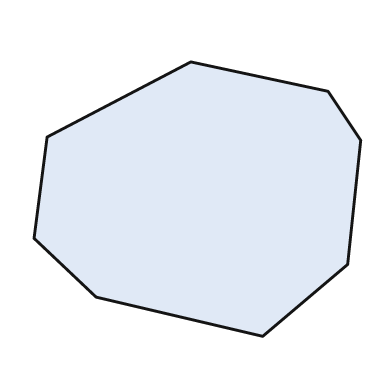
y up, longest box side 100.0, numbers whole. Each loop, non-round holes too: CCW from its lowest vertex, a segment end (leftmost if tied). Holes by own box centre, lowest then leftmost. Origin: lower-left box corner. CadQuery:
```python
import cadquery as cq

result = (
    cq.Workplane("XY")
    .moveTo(70.0, 0.0)
    .lineTo(96.0, 22.0)
    .lineTo(100.0, 60.0)
    .lineTo(90.0, 75.0)
    .lineTo(48.0, 84.0)
    .lineTo(4.0, 61.0)
    .lineTo(0.0, 30.0)
    .lineTo(19.0, 12.0)
    .close()
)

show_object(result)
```